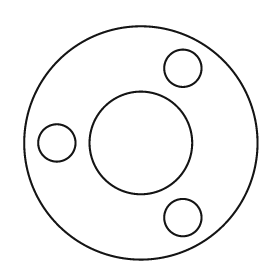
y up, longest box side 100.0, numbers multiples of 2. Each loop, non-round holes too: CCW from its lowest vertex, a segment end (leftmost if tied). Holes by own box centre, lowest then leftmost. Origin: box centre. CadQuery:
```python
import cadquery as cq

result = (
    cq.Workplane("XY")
    .moveTo(0.0, 0.0)
    .circle(50.0)
    .moveTo(18.0, -32.0)
    .circle(8.0)
    .moveTo(-36.0, 0.0)
    .circle(8.0)
    .moveTo(0.0, 0.0)
    .circle(22.0)
    .moveTo(18.0, 32.0)
    .circle(8.0)
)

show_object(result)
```